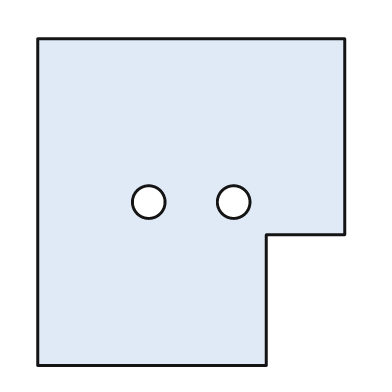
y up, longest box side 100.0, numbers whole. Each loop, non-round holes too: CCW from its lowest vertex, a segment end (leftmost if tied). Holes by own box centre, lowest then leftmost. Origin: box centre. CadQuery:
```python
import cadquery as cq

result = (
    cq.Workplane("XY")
    .moveTo(-47.0, -50.0)
    .lineTo(23.0, -50.0)
    .lineTo(23.0, -10.0)
    .lineTo(47.0, -10.0)
    .lineTo(47.0, 50.0)
    .lineTo(-47.0, 50.0)
    .close()
    .moveTo(-13.0, 0.0)
    .circle(5.0)
    .moveTo(13.0, 0.0)
    .circle(5.0)
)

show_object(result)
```